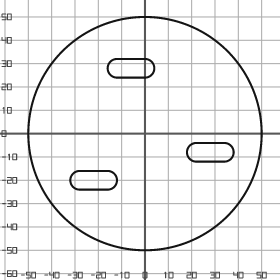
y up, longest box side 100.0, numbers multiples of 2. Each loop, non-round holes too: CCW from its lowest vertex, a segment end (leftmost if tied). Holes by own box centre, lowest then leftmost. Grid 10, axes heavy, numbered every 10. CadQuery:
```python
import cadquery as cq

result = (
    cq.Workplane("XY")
    .moveTo(0.0, 0.0)
    .circle(50.0)
    .moveTo(-28.0, -24.0)
    .lineTo(-16.0, -24.0)
    .threePointArc((-12.0, -20.0), (-16.0, -16.0))
    .lineTo(-28.0, -16.0)
    .threePointArc((-32.0, -20.0), (-28.0, -24.0))
    .close()
    .moveTo(22.0, -12.0)
    .lineTo(34.0, -12.0)
    .threePointArc((38.0, -8.0), (34.0, -4.0))
    .lineTo(22.0, -4.0)
    .threePointArc((18.0, -8.0), (22.0, -12.0))
    .close()
    .moveTo(-12.0, 24.0)
    .lineTo(0.0, 24.0)
    .threePointArc((4.0, 28.0), (0.0, 32.0))
    .lineTo(-12.0, 32.0)
    .threePointArc((-16.0, 28.0), (-12.0, 24.0))
    .close()
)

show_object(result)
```